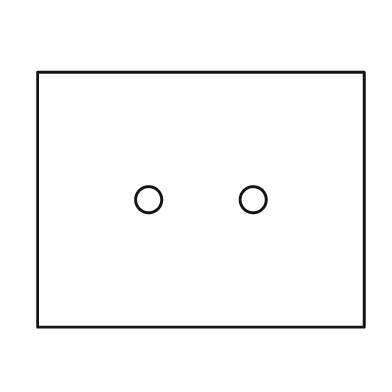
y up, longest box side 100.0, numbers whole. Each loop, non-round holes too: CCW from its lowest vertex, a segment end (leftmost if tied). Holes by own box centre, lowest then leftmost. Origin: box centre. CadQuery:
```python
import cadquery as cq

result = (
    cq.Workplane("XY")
    .moveTo(-50.0, -39.0)
    .lineTo(50.0, -39.0)
    .lineTo(50.0, 39.0)
    .lineTo(-50.0, 39.0)
    .close()
    .moveTo(-16.0, 0.0)
    .circle(4.0)
    .moveTo(16.0, 0.0)
    .circle(4.0)
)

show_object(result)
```